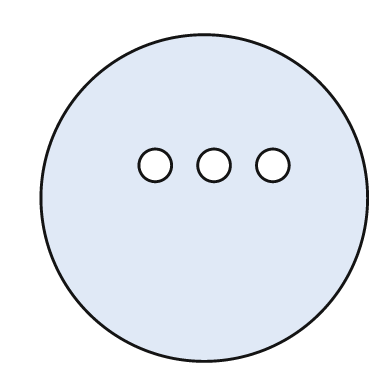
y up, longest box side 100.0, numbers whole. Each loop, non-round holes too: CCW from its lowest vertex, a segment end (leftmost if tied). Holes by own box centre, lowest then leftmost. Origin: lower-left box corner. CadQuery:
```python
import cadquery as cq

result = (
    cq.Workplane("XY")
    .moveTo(50.0, 50.0)
    .circle(50.0)
    .moveTo(35.0, 60.0)
    .circle(5.0)
    .moveTo(53.0, 60.0)
    .circle(5.0)
    .moveTo(71.0, 60.0)
    .circle(5.0)
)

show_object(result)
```